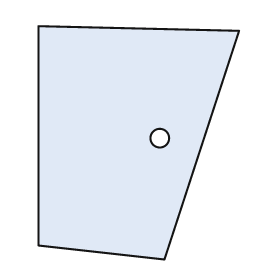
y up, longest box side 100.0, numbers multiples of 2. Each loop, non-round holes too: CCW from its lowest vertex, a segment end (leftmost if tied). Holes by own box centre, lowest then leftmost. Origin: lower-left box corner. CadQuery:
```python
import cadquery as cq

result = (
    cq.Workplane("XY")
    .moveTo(54.0, 0.0)
    .lineTo(86.0, 98.0)
    .lineTo(0.0, 100.0)
    .lineTo(0.0, 6.0)
    .close()
    .moveTo(52.0, 52.0)
    .circle(4.0)
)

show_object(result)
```